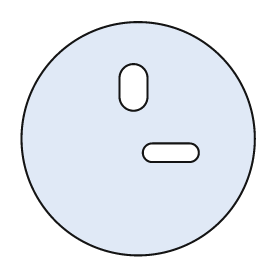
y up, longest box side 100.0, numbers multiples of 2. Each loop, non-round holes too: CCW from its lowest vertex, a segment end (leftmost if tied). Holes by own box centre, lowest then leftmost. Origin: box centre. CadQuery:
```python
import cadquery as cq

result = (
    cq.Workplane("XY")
    .moveTo(0.0, 0.0)
    .circle(50.0)
    .moveTo(6.0, -10.0)
    .lineTo(22.0, -10.0)
    .threePointArc((26.0, -6.0), (22.0, -2.0))
    .lineTo(6.0, -2.0)
    .threePointArc((2.0, -6.0), (6.0, -10.0))
    .close()
    .moveTo(-8.0, 18.0)
    .threePointArc((-2.0, 12.0), (4.0, 18.0))
    .lineTo(4.0, 26.0)
    .threePointArc((-2.0, 32.0), (-8.0, 26.0))
    .close()
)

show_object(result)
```